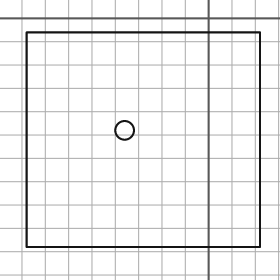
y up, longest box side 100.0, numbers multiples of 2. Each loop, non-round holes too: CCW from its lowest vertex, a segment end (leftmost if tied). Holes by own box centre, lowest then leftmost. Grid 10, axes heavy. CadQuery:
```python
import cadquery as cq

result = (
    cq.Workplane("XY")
    .moveTo(-78.0, -98.0)
    .lineTo(22.0, -98.0)
    .lineTo(22.0, -6.0)
    .lineTo(-78.0, -6.0)
    .close()
    .moveTo(-36.0, -48.0)
    .circle(4.0)
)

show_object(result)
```